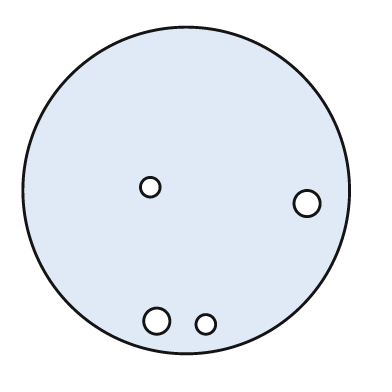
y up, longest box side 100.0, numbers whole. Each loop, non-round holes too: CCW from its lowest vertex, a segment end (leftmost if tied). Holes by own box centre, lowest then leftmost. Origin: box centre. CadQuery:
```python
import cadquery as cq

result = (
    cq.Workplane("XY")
    .moveTo(0.0, 0.0)
    .circle(50.0)
    .moveTo(6.0, -41.0)
    .circle(3.0)
    .moveTo(-9.0, -40.0)
    .circle(4.0)
    .moveTo(37.0, -4.0)
    .circle(4.0)
    .moveTo(-11.0, 1.0)
    .circle(3.0)
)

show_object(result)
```